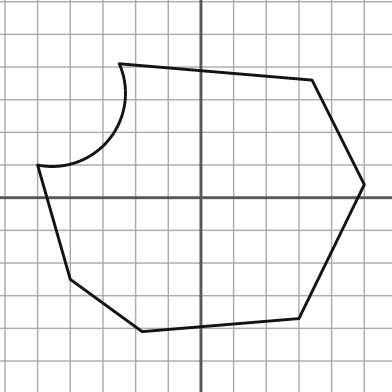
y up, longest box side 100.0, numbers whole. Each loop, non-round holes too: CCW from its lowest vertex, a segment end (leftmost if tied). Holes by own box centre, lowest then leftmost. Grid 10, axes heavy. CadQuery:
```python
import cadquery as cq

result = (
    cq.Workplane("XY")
    .moveTo(-18.0, -41.0)
    .lineTo(30.0, -37.0)
    .lineTo(50.0, 4.0)
    .lineTo(34.0, 36.0)
    .lineTo(-25.0, 41.0)
    .threePointArc((-28.0, 18.0), (-50.0, 10.0))
    .lineTo(-40.0, -25.0)
    .close()
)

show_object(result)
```